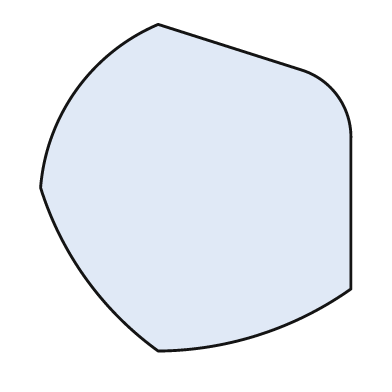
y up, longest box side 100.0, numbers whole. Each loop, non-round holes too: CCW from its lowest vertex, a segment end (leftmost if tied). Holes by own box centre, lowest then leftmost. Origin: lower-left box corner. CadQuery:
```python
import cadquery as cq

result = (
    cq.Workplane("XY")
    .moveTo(36.0, 0.0)
    .threePointArc((67.0, 5.0), (95.0, 19.0))
    .lineTo(95.0, 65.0)
    .threePointArc((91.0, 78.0), (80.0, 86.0))
    .lineTo(36.0, 100.0)
    .threePointArc((11.0, 80.0), (0.0, 50.0))
    .threePointArc((14.0, 22.0), (36.0, 0.0))
    .close()
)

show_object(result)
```